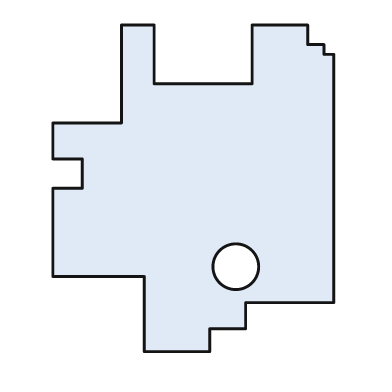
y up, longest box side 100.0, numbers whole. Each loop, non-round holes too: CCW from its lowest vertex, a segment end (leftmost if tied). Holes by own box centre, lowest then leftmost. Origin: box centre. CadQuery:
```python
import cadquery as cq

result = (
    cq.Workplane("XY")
    .moveTo(-15.0, -50.0)
    .lineTo(5.0, -50.0)
    .lineTo(5.0, -43.0)
    .lineTo(16.0, -43.0)
    .lineTo(16.0, -35.0)
    .lineTo(43.0, -35.0)
    .lineTo(43.0, 41.0)
    .lineTo(40.0, 41.0)
    .lineTo(40.0, 44.0)
    .lineTo(35.0, 44.0)
    .lineTo(35.0, 50.0)
    .lineTo(18.0, 50.0)
    .lineTo(18.0, 32.0)
    .lineTo(-12.0, 32.0)
    .lineTo(-12.0, 50.0)
    .lineTo(-22.0, 50.0)
    .lineTo(-22.0, 20.0)
    .lineTo(-43.0, 20.0)
    .lineTo(-43.0, 9.0)
    .lineTo(-34.0, 9.0)
    .lineTo(-34.0, 0.0)
    .lineTo(-43.0, 0.0)
    .lineTo(-43.0, -27.0)
    .lineTo(-15.0, -27.0)
    .close()
    .moveTo(13.0, -24.0)
    .circle(7.0)
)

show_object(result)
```